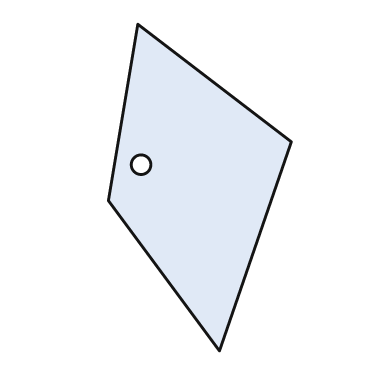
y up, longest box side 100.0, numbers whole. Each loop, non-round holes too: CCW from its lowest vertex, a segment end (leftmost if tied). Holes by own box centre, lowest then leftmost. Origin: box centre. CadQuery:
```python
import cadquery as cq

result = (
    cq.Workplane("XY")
    .moveTo(6.0, -50.0)
    .lineTo(28.0, 14.0)
    .lineTo(-19.0, 50.0)
    .lineTo(-28.0, -4.0)
    .close()
    .moveTo(-18.0, 7.0)
    .circle(3.0)
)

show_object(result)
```